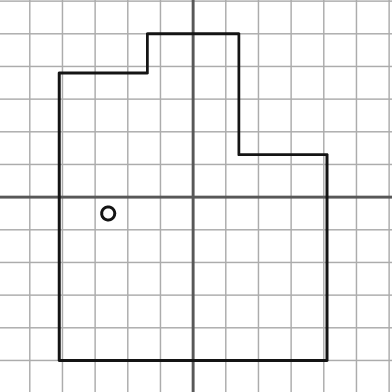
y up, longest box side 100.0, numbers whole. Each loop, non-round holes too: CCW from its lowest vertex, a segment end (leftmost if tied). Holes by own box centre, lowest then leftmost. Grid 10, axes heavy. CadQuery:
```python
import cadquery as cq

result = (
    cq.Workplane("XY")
    .moveTo(-41.0, -50.0)
    .lineTo(41.0, -50.0)
    .lineTo(41.0, 13.0)
    .lineTo(14.0, 13.0)
    .lineTo(14.0, 50.0)
    .lineTo(-14.0, 50.0)
    .lineTo(-14.0, 38.0)
    .lineTo(-41.0, 38.0)
    .close()
    .moveTo(-26.0, -5.0)
    .circle(2.0)
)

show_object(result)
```